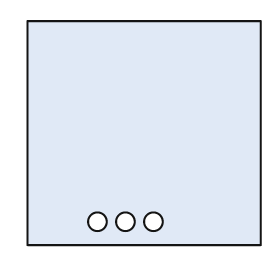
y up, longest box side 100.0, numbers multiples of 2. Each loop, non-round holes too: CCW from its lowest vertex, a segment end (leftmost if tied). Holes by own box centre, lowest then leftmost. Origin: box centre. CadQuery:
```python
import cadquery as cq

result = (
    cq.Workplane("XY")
    .moveTo(-50.0, -48.0)
    .lineTo(50.0, -48.0)
    .lineTo(50.0, 48.0)
    .lineTo(-50.0, 48.0)
    .close()
    .moveTo(-20.0, -38.0)
    .circle(4.0)
    .moveTo(-8.0, -38.0)
    .circle(4.0)
    .moveTo(4.0, -38.0)
    .circle(4.0)
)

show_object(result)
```